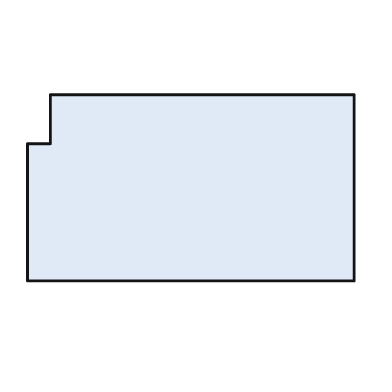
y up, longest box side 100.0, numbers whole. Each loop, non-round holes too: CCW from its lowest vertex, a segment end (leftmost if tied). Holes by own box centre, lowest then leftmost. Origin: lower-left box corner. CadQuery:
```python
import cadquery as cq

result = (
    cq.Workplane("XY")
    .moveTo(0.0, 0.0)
    .lineTo(100.0, 0.0)
    .lineTo(100.0, 57.0)
    .lineTo(7.0, 57.0)
    .lineTo(7.0, 42.0)
    .lineTo(0.0, 42.0)
    .close()
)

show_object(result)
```